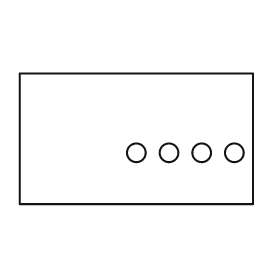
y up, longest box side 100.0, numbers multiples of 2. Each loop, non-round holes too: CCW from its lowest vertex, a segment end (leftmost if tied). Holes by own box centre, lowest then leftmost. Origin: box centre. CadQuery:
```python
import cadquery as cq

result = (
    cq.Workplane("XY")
    .moveTo(-50.0, -28.0)
    .lineTo(50.0, -28.0)
    .lineTo(50.0, 28.0)
    .lineTo(-50.0, 28.0)
    .close()
    .moveTo(0.0, -6.0)
    .circle(4.0)
    .moveTo(14.0, -6.0)
    .circle(4.0)
    .moveTo(28.0, -6.0)
    .circle(4.0)
    .moveTo(42.0, -6.0)
    .circle(4.0)
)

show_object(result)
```